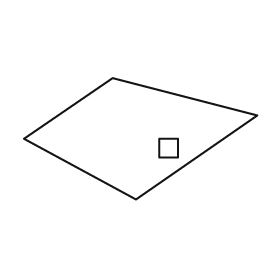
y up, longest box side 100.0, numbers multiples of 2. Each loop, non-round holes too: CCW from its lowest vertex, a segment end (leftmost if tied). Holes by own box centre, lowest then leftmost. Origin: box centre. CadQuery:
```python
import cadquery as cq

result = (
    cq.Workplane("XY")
    .moveTo(-2.0, -26.0)
    .lineTo(50.0, 10.0)
    .lineTo(-12.0, 26.0)
    .lineTo(-50.0, 0.0)
    .close()
    .moveTo(8.0, -8.0)
    .lineTo(16.0, -8.0)
    .lineTo(16.0, 0.0)
    .lineTo(8.0, 0.0)
    .close()
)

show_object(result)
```